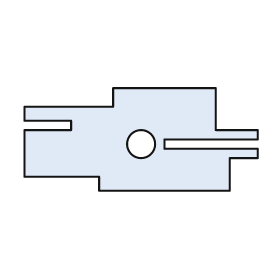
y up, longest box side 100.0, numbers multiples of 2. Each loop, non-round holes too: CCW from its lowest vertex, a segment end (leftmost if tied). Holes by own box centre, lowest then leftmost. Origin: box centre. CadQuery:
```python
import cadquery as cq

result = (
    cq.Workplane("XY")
    .moveTo(-18.0, -22.0)
    .lineTo(38.0, -22.0)
    .lineTo(38.0, -8.0)
    .lineTo(50.0, -8.0)
    .lineTo(50.0, -4.0)
    .lineTo(10.0, -4.0)
    .lineTo(10.0, 0.0)
    .lineTo(50.0, 0.0)
    .lineTo(50.0, 4.0)
    .lineTo(32.0, 4.0)
    .lineTo(32.0, 22.0)
    .lineTo(-12.0, 22.0)
    .lineTo(-12.0, 14.0)
    .lineTo(-50.0, 14.0)
    .lineTo(-50.0, 8.0)
    .lineTo(-30.0, 8.0)
    .lineTo(-30.0, 4.0)
    .lineTo(-50.0, 4.0)
    .lineTo(-50.0, -16.0)
    .lineTo(-18.0, -16.0)
    .close()
    .moveTo(0.0, -2.0)
    .circle(6.0)
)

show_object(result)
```